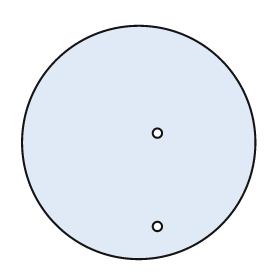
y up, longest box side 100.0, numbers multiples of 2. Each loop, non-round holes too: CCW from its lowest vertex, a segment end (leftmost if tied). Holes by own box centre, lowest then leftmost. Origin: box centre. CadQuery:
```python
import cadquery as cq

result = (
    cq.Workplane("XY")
    .moveTo(0.0, 0.0)
    .circle(50.0)
    .moveTo(8.0, -36.0)
    .circle(2.0)
    .moveTo(8.0, 4.0)
    .circle(2.0)
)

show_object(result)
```